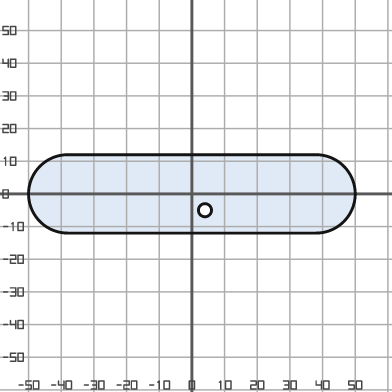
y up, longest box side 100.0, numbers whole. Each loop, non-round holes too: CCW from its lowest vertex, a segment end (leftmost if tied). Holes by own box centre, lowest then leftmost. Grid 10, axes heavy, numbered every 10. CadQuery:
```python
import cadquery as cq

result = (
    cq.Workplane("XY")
    .moveTo(-38.0, -12.0)
    .lineTo(38.0, -12.0)
    .threePointArc((50.0, 0.0), (38.0, 12.0))
    .lineTo(-38.0, 12.0)
    .threePointArc((-50.0, 0.0), (-38.0, -12.0))
    .close()
    .moveTo(4.0, -5.0)
    .circle(2.0)
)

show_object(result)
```